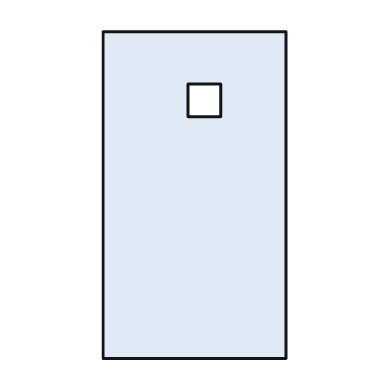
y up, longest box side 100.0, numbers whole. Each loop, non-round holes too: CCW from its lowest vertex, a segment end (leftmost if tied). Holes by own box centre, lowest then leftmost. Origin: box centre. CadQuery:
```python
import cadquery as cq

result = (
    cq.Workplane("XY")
    .moveTo(-28.0, -50.0)
    .lineTo(28.0, -50.0)
    .lineTo(28.0, 50.0)
    .lineTo(-28.0, 50.0)
    .close()
    .moveTo(-2.0, 24.0)
    .lineTo(8.0, 24.0)
    .lineTo(8.0, 34.0)
    .lineTo(-2.0, 34.0)
    .close()
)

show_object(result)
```